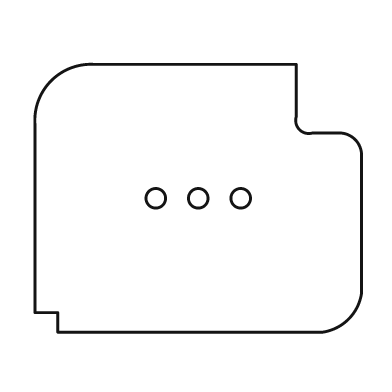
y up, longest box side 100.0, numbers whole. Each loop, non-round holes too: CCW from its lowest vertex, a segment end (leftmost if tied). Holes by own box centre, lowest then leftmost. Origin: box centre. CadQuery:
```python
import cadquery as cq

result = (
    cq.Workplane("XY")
    .moveTo(-43.0, -41.0)
    .lineTo(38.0, -41.0)
    .threePointArc((46.0, -37.0), (50.0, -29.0))
    .lineTo(50.0, 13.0)
    .threePointArc((48.0, 18.0), (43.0, 20.0))
    .lineTo(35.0, 20.0)
    .threePointArc((31.0, 21.0), (30.0, 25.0))
    .lineTo(30.0, 41.0)
    .lineTo(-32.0, 41.0)
    .threePointArc((-45.0, 36.0), (-50.0, 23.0))
    .lineTo(-50.0, -35.0)
    .lineTo(-43.0, -35.0)
    .close()
    .moveTo(-13.0, 0.0)
    .circle(3.0)
    .moveTo(0.0, 0.0)
    .circle(3.0)
    .moveTo(13.0, 0.0)
    .circle(3.0)
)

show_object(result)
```